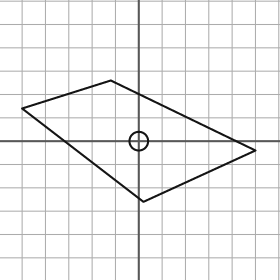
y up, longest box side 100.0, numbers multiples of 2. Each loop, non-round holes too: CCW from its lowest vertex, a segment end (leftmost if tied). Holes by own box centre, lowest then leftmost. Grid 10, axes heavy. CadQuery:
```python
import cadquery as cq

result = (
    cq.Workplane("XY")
    .moveTo(2.0, -26.0)
    .lineTo(50.0, -4.0)
    .lineTo(-12.0, 26.0)
    .lineTo(-50.0, 14.0)
    .close()
    .moveTo(0.0, 0.0)
    .circle(4.0)
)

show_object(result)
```